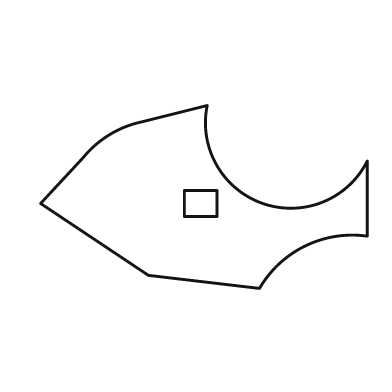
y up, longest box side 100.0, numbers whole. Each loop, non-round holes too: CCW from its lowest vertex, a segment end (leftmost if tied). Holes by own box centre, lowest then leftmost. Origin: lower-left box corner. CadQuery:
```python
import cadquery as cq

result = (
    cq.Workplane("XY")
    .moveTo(67.0, 0.0)
    .threePointArc((81.0, 13.0), (100.0, 16.0))
    .lineTo(100.0, 39.0)
    .threePointArc((68.0, 26.0), (51.0, 56.0))
    .lineTo(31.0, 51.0)
    .threePointArc((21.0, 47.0), (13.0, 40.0))
    .lineTo(0.0, 26.0)
    .lineTo(33.0, 4.0)
    .close()
    .moveTo(44.0, 22.0)
    .lineTo(54.0, 22.0)
    .lineTo(54.0, 30.0)
    .lineTo(44.0, 30.0)
    .close()
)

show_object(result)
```